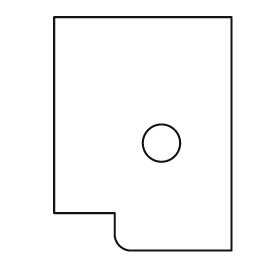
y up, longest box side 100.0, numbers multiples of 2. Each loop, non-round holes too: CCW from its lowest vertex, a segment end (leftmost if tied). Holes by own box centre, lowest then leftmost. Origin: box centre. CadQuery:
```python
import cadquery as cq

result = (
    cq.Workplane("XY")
    .moveTo(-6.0, -50.0)
    .lineTo(38.0, -50.0)
    .lineTo(38.0, 50.0)
    .lineTo(-38.0, 50.0)
    .lineTo(-38.0, -34.0)
    .lineTo(-12.0, -34.0)
    .lineTo(-12.0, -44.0)
    .threePointArc((-10.0, -48.0), (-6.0, -50.0))
    .close()
    .moveTo(8.0, -4.0)
    .circle(8.0)
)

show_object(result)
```